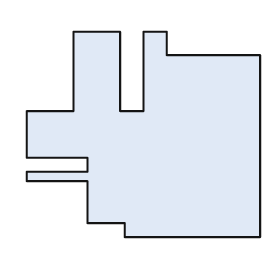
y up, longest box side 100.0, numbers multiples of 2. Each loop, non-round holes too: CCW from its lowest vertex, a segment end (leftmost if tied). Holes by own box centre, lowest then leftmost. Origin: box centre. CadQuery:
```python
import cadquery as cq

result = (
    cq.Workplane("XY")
    .moveTo(-8.0, -44.0)
    .lineTo(50.0, -44.0)
    .lineTo(50.0, 34.0)
    .lineTo(10.0, 34.0)
    .lineTo(10.0, 44.0)
    .lineTo(0.0, 44.0)
    .lineTo(0.0, 10.0)
    .lineTo(-10.0, 10.0)
    .lineTo(-10.0, 44.0)
    .lineTo(-30.0, 44.0)
    .lineTo(-30.0, 10.0)
    .lineTo(-50.0, 10.0)
    .lineTo(-50.0, -10.0)
    .lineTo(-24.0, -10.0)
    .lineTo(-24.0, -16.0)
    .lineTo(-50.0, -16.0)
    .lineTo(-50.0, -20.0)
    .lineTo(-24.0, -20.0)
    .lineTo(-24.0, -38.0)
    .lineTo(-8.0, -38.0)
    .close()
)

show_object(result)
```